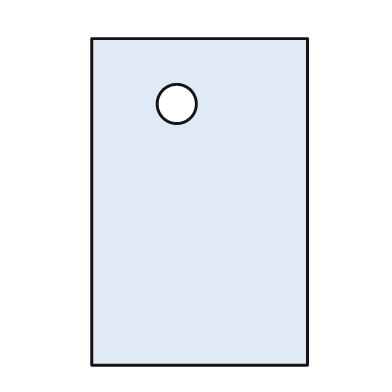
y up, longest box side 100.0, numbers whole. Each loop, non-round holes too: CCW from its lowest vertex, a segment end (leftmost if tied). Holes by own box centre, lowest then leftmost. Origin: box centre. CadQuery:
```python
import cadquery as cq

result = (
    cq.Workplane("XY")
    .moveTo(-33.0, -50.0)
    .lineTo(33.0, -50.0)
    .lineTo(33.0, 50.0)
    .lineTo(-33.0, 50.0)
    .close()
    .moveTo(-7.0, 30.0)
    .circle(6.0)
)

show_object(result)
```